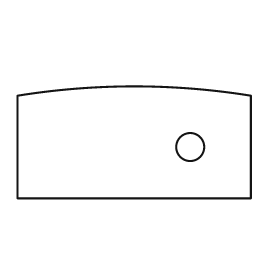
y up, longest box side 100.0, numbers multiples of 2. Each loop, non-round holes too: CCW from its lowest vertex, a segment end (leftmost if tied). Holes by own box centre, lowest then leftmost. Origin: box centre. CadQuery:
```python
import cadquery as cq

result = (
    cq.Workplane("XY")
    .moveTo(-50.0, -24.0)
    .lineTo(50.0, -24.0)
    .lineTo(50.0, 20.0)
    .threePointArc((0.0, 24.0), (-50.0, 20.0))
    .close()
    .moveTo(24.0, -2.0)
    .circle(6.0)
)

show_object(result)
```